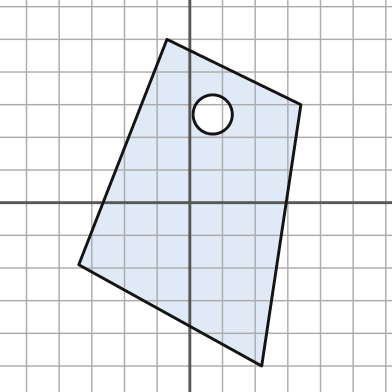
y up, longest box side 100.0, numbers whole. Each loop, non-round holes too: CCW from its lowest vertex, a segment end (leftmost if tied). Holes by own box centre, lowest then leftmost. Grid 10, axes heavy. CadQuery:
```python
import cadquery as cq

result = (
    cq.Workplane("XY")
    .moveTo(22.0, -50.0)
    .lineTo(34.0, 30.0)
    .lineTo(-7.0, 50.0)
    .lineTo(-34.0, -19.0)
    .close()
    .moveTo(7.0, 27.0)
    .circle(6.0)
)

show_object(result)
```